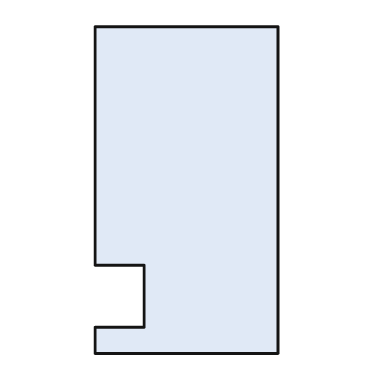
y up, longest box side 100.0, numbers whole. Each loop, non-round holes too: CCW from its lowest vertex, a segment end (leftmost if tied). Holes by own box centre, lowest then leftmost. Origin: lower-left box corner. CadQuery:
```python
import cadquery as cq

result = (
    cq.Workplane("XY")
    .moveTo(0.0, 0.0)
    .lineTo(56.0, 0.0)
    .lineTo(56.0, 100.0)
    .lineTo(0.0, 100.0)
    .lineTo(0.0, 27.0)
    .lineTo(15.0, 27.0)
    .lineTo(15.0, 8.0)
    .lineTo(0.0, 8.0)
    .close()
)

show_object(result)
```